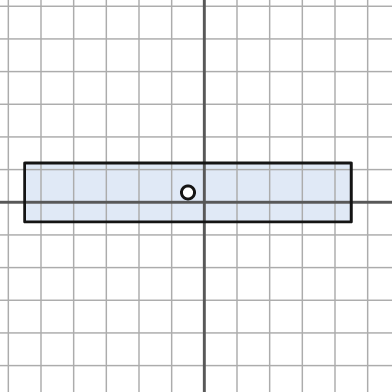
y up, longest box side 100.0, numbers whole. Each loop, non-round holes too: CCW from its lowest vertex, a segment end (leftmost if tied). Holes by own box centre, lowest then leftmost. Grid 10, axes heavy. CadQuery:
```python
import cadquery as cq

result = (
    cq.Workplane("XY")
    .moveTo(-55.0, -6.0)
    .lineTo(45.0, -6.0)
    .lineTo(45.0, 12.0)
    .lineTo(-55.0, 12.0)
    .close()
    .moveTo(-5.0, 3.0)
    .circle(2.0)
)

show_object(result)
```